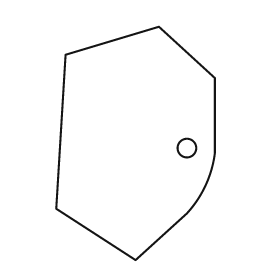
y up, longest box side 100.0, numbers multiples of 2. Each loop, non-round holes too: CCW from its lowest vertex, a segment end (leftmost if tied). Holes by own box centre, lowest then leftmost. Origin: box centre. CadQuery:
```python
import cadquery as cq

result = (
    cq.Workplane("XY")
    .moveTo(0.0, -50.0)
    .lineTo(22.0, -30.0)
    .threePointArc((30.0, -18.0), (34.0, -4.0))
    .lineTo(34.0, 28.0)
    .lineTo(10.0, 50.0)
    .lineTo(-30.0, 38.0)
    .lineTo(-34.0, -28.0)
    .close()
    .moveTo(22.0, -2.0)
    .circle(4.0)
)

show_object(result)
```